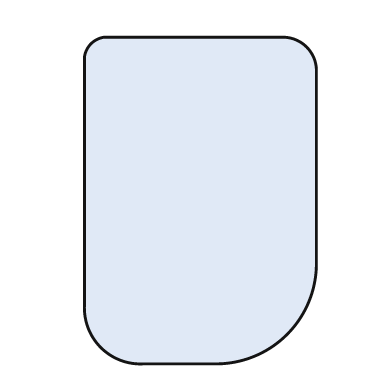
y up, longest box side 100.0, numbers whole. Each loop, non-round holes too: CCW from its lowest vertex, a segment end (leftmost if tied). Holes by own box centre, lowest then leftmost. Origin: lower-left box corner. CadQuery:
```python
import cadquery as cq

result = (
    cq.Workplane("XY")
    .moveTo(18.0, 0.0)
    .lineTo(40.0, 0.0)
    .threePointArc((62.0, 9.0), (71.0, 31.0))
    .lineTo(71.0, 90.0)
    .threePointArc((68.0, 97.0), (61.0, 100.0))
    .lineTo(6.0, 100.0)
    .threePointArc((2.0, 98.0), (0.0, 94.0))
    .lineTo(0.0, 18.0)
    .threePointArc((5.0, 5.0), (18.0, 0.0))
    .close()
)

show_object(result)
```